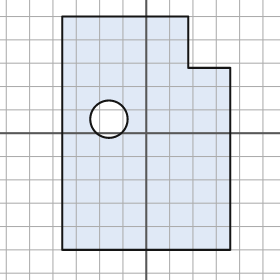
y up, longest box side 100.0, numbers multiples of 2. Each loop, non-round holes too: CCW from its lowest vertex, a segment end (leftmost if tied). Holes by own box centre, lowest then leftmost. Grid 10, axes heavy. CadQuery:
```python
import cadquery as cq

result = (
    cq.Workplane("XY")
    .moveTo(-36.0, -50.0)
    .lineTo(36.0, -50.0)
    .lineTo(36.0, 28.0)
    .lineTo(18.0, 28.0)
    .lineTo(18.0, 50.0)
    .lineTo(-36.0, 50.0)
    .close()
    .moveTo(-16.0, 6.0)
    .circle(8.0)
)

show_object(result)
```